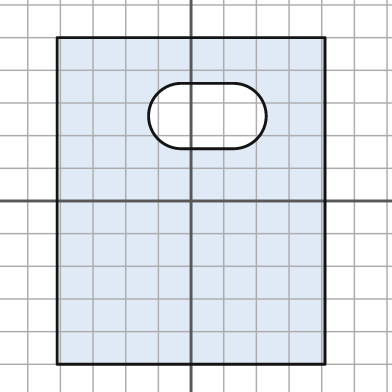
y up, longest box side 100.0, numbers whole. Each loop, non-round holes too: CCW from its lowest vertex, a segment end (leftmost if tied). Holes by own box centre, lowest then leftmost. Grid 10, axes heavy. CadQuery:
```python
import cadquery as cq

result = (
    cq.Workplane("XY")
    .moveTo(-41.0, -50.0)
    .lineTo(41.0, -50.0)
    .lineTo(41.0, 50.0)
    .lineTo(-41.0, 50.0)
    .close()
    .moveTo(-3.0, 16.0)
    .lineTo(13.0, 16.0)
    .threePointArc((23.0, 26.0), (13.0, 36.0))
    .lineTo(-3.0, 36.0)
    .threePointArc((-13.0, 26.0), (-3.0, 16.0))
    .close()
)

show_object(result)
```